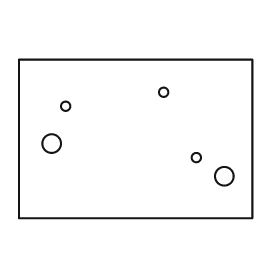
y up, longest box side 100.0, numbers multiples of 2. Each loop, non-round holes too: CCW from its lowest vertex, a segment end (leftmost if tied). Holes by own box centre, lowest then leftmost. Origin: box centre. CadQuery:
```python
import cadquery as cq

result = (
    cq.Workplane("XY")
    .moveTo(-50.0, -34.0)
    .lineTo(50.0, -34.0)
    .lineTo(50.0, 34.0)
    .lineTo(-50.0, 34.0)
    .close()
    .moveTo(38.0, -16.0)
    .circle(4.0)
    .moveTo(26.0, -8.0)
    .circle(2.0)
    .moveTo(-36.0, -2.0)
    .circle(4.0)
    .moveTo(-30.0, 14.0)
    .circle(2.0)
    .moveTo(12.0, 20.0)
    .circle(2.0)
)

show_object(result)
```